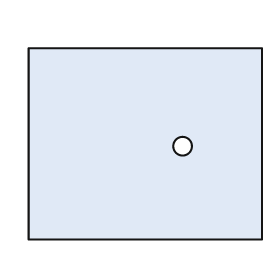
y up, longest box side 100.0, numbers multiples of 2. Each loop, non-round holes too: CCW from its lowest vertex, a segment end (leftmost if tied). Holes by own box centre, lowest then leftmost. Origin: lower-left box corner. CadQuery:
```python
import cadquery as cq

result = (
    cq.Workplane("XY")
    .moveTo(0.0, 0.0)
    .lineTo(100.0, 0.0)
    .lineTo(100.0, 82.0)
    .lineTo(0.0, 82.0)
    .close()
    .moveTo(66.0, 40.0)
    .circle(4.0)
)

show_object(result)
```